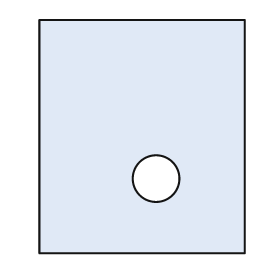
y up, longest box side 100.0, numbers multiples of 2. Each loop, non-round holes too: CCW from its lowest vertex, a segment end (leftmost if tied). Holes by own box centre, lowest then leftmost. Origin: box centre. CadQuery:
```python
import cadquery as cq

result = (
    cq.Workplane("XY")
    .moveTo(-44.0, -50.0)
    .lineTo(44.0, -50.0)
    .lineTo(44.0, 50.0)
    .lineTo(-44.0, 50.0)
    .close()
    .moveTo(6.0, -18.0)
    .circle(10.0)
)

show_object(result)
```